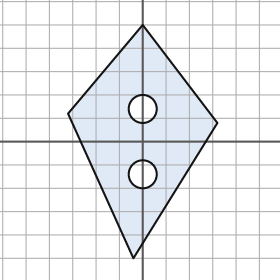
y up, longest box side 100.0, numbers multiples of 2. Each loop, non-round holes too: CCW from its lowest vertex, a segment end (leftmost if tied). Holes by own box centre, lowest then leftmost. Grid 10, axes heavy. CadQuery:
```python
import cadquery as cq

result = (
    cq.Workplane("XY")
    .moveTo(-4.0, -50.0)
    .lineTo(32.0, 8.0)
    .lineTo(0.0, 50.0)
    .lineTo(-32.0, 12.0)
    .close()
    .moveTo(0.0, -14.0)
    .circle(6.0)
    .moveTo(0.0, 14.0)
    .circle(6.0)
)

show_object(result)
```